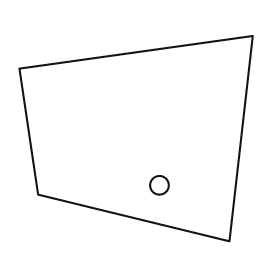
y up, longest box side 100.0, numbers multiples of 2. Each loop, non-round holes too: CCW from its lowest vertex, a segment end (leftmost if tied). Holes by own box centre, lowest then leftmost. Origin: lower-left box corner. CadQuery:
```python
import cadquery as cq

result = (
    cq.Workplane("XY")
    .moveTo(90.0, 0.0)
    .lineTo(100.0, 88.0)
    .lineTo(0.0, 74.0)
    .lineTo(8.0, 20.0)
    .close()
    .moveTo(60.0, 24.0)
    .circle(4.0)
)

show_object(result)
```